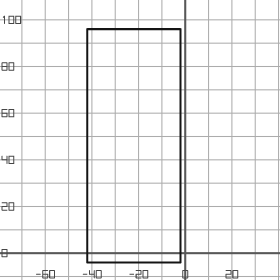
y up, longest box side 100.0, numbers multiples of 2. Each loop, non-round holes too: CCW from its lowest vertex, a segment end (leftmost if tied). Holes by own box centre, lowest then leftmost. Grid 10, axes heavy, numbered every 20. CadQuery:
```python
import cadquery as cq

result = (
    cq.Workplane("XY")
    .moveTo(-42.0, -4.0)
    .lineTo(-2.0, -4.0)
    .lineTo(-2.0, 96.0)
    .lineTo(-42.0, 96.0)
    .close()
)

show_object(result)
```